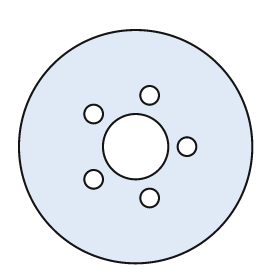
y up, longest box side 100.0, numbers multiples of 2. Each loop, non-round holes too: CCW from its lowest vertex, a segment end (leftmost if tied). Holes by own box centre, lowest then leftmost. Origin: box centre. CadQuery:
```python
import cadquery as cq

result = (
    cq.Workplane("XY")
    .moveTo(0.0, 0.0)
    .circle(50.0)
    .moveTo(6.0, -22.0)
    .circle(4.0)
    .moveTo(-18.0, -14.0)
    .circle(4.0)
    .moveTo(0.0, 0.0)
    .circle(14.0)
    .moveTo(22.0, 0.0)
    .circle(4.0)
    .moveTo(-18.0, 14.0)
    .circle(4.0)
    .moveTo(6.0, 22.0)
    .circle(4.0)
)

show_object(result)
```